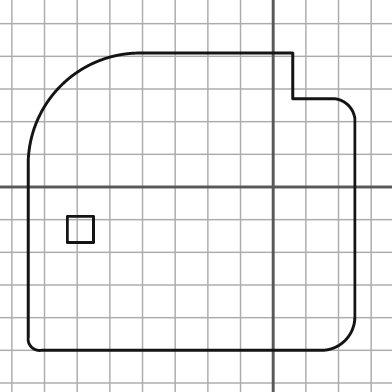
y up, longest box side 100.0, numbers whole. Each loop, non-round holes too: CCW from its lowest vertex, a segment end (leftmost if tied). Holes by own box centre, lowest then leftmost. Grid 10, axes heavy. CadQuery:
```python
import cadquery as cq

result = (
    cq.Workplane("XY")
    .moveTo(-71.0, -50.0)
    .lineTo(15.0, -50.0)
    .threePointArc((22.0, -47.0), (25.0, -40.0))
    .lineTo(25.0, 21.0)
    .threePointArc((23.0, 25.0), (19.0, 27.0))
    .lineTo(6.0, 27.0)
    .lineTo(6.0, 41.0)
    .lineTo(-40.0, 41.0)
    .threePointArc((-65.0, 31.0), (-75.0, 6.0))
    .lineTo(-75.0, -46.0)
    .threePointArc((-74.0, -49.0), (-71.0, -50.0))
    .close()
    .moveTo(-63.0, -17.0)
    .lineTo(-55.0, -17.0)
    .lineTo(-55.0, -9.0)
    .lineTo(-63.0, -9.0)
    .close()
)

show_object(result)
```